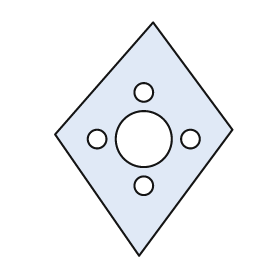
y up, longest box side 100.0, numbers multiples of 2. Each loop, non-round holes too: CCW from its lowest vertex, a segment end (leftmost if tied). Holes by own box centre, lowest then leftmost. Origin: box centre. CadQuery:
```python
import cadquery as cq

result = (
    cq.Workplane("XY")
    .moveTo(-2.0, -50.0)
    .lineTo(38.0, 4.0)
    .lineTo(4.0, 50.0)
    .lineTo(-38.0, 2.0)
    .close()
    .moveTo(0.0, -20.0)
    .circle(4.0)
    .moveTo(-20.0, 0.0)
    .circle(4.0)
    .moveTo(0.0, 0.0)
    .circle(12.0)
    .moveTo(20.0, 0.0)
    .circle(4.0)
    .moveTo(0.0, 20.0)
    .circle(4.0)
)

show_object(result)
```